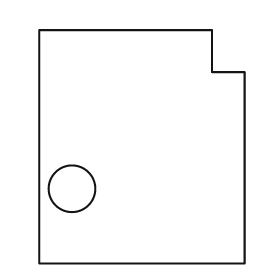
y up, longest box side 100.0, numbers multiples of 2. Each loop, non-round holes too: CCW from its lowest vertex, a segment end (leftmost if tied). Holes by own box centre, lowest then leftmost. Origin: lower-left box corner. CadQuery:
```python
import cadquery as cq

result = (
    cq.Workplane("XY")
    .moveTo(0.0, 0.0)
    .lineTo(88.0, 0.0)
    .lineTo(88.0, 82.0)
    .lineTo(74.0, 82.0)
    .lineTo(74.0, 100.0)
    .lineTo(0.0, 100.0)
    .close()
    .moveTo(14.0, 32.0)
    .circle(10.0)
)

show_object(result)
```